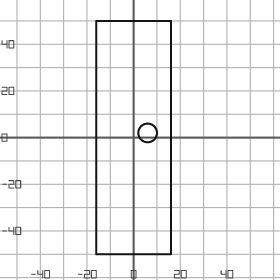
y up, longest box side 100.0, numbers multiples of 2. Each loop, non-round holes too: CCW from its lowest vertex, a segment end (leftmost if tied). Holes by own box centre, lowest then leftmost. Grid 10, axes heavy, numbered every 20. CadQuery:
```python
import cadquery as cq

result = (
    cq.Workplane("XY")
    .moveTo(-16.0, -50.0)
    .lineTo(16.0, -50.0)
    .lineTo(16.0, 50.0)
    .lineTo(-16.0, 50.0)
    .close()
    .moveTo(6.0, 2.0)
    .circle(4.0)
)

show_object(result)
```